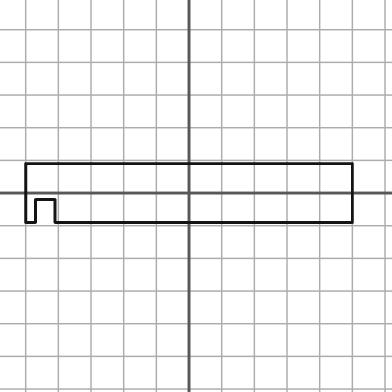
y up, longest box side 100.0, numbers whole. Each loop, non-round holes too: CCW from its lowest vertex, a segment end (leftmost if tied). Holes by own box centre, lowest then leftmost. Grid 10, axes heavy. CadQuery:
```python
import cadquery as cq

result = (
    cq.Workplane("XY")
    .moveTo(-50.0, -9.0)
    .lineTo(-47.0, -9.0)
    .lineTo(-47.0, -2.0)
    .lineTo(-41.0, -2.0)
    .lineTo(-41.0, -9.0)
    .lineTo(50.0, -9.0)
    .lineTo(50.0, 9.0)
    .lineTo(-50.0, 9.0)
    .close()
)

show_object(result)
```